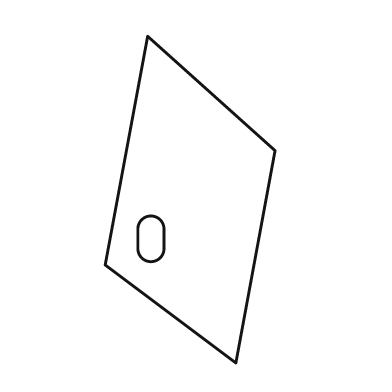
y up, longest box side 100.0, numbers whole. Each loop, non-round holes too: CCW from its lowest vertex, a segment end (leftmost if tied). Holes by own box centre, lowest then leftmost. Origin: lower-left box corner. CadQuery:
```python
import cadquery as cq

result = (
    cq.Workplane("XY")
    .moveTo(40.0, 0.0)
    .lineTo(52.0, 65.0)
    .lineTo(13.0, 100.0)
    .lineTo(0.0, 30.0)
    .close()
    .moveTo(10.0, 35.0)
    .threePointArc((14.0, 31.0), (18.0, 35.0))
    .lineTo(18.0, 41.0)
    .threePointArc((14.0, 45.0), (10.0, 41.0))
    .close()
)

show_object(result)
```